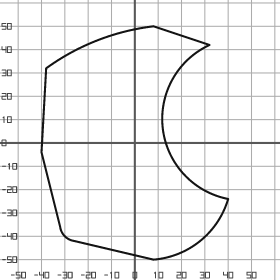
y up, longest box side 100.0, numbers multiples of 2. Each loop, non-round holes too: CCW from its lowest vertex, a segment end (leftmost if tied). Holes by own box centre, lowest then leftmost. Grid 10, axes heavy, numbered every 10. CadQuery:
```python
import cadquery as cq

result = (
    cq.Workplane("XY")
    .moveTo(8.0, -50.0)
    .threePointArc((28.0, -42.0), (40.0, -24.0))
    .threePointArc((12.0, 6.0), (32.0, 42.0))
    .lineTo(8.0, 50.0)
    .threePointArc((-16.0, 44.0), (-38.0, 32.0))
    .lineTo(-40.0, -4.0)
    .lineTo(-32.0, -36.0)
    .threePointArc((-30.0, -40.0), (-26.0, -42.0))
    .close()
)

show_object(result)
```